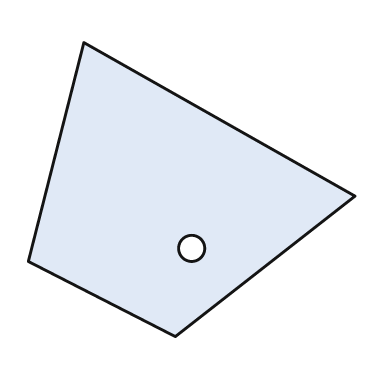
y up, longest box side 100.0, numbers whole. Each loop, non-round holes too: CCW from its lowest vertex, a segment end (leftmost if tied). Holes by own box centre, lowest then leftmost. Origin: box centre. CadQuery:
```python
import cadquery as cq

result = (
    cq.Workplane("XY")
    .moveTo(-5.0, -45.0)
    .lineTo(50.0, -2.0)
    .lineTo(-33.0, 45.0)
    .lineTo(-50.0, -22.0)
    .close()
    .moveTo(0.0, -18.0)
    .circle(4.0)
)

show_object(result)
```